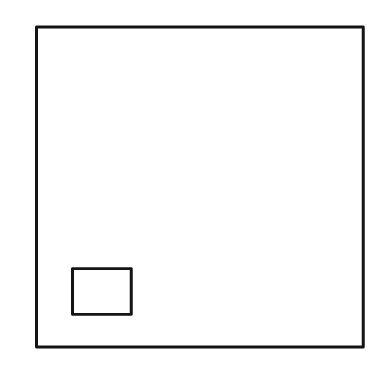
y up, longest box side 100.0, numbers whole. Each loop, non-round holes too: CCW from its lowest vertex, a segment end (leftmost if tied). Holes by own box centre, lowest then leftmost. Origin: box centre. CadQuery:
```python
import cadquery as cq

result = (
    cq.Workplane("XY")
    .moveTo(-50.0, -49.0)
    .lineTo(50.0, -49.0)
    .lineTo(50.0, 49.0)
    .lineTo(-50.0, 49.0)
    .close()
    .moveTo(-39.0, -39.0)
    .lineTo(-21.0, -39.0)
    .lineTo(-21.0, -25.0)
    .lineTo(-39.0, -25.0)
    .close()
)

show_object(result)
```